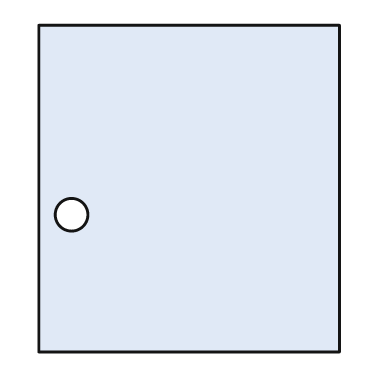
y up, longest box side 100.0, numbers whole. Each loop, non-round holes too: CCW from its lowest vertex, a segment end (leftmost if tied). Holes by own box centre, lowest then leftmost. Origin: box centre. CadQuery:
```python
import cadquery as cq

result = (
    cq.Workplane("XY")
    .moveTo(-46.0, -50.0)
    .lineTo(46.0, -50.0)
    .lineTo(46.0, 50.0)
    .lineTo(-46.0, 50.0)
    .close()
    .moveTo(-36.0, -8.0)
    .circle(5.0)
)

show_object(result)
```